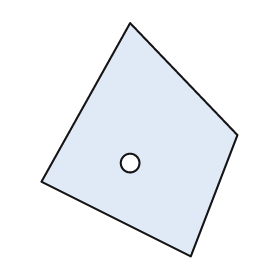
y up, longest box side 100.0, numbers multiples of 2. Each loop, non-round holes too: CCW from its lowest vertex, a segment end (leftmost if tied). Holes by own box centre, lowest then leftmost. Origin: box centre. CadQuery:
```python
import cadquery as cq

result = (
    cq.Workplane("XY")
    .moveTo(22.0, -50.0)
    .lineTo(42.0, 2.0)
    .lineTo(-4.0, 50.0)
    .lineTo(-42.0, -18.0)
    .close()
    .moveTo(-4.0, -10.0)
    .circle(4.0)
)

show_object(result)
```